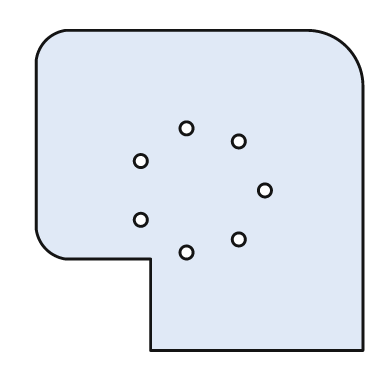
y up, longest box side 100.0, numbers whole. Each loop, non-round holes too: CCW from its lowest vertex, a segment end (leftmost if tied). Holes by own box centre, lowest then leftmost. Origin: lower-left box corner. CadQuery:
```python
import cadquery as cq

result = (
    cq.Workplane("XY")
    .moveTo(35.0, 0.0)
    .lineTo(100.0, 0.0)
    .lineTo(100.0, 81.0)
    .threePointArc((95.0, 93.0), (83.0, 98.0))
    .lineTo(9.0, 98.0)
    .threePointArc((3.0, 95.0), (0.0, 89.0))
    .lineTo(0.0, 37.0)
    .threePointArc((3.0, 31.0), (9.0, 28.0))
    .lineTo(35.0, 28.0)
    .close()
    .moveTo(46.0, 30.0)
    .circle(2.0)
    .moveTo(62.0, 34.0)
    .circle(2.0)
    .moveTo(32.0, 40.0)
    .circle(2.0)
    .moveTo(70.0, 49.0)
    .circle(2.0)
    .moveTo(32.0, 58.0)
    .circle(2.0)
    .moveTo(62.0, 64.0)
    .circle(2.0)
    .moveTo(46.0, 68.0)
    .circle(2.0)
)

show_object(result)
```